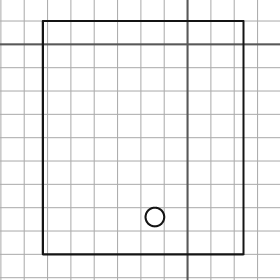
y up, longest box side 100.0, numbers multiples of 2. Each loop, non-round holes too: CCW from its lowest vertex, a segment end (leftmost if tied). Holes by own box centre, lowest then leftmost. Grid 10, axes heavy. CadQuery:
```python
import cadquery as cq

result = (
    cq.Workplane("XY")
    .moveTo(-62.0, -90.0)
    .lineTo(24.0, -90.0)
    .lineTo(24.0, 10.0)
    .lineTo(-62.0, 10.0)
    .close()
    .moveTo(-14.0, -74.0)
    .circle(4.0)
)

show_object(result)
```